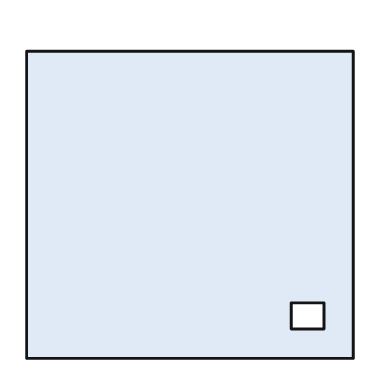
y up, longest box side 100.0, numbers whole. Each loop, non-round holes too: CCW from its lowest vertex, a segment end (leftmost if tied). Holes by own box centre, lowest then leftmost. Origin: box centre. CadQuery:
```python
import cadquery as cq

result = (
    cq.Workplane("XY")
    .moveTo(-50.0, -47.0)
    .lineTo(50.0, -47.0)
    .lineTo(50.0, 47.0)
    .lineTo(-50.0, 47.0)
    .close()
    .moveTo(31.0, -38.0)
    .lineTo(41.0, -38.0)
    .lineTo(41.0, -30.0)
    .lineTo(31.0, -30.0)
    .close()
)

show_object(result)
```